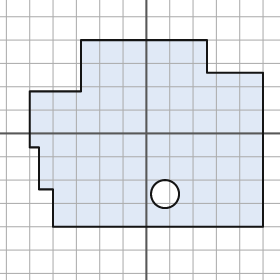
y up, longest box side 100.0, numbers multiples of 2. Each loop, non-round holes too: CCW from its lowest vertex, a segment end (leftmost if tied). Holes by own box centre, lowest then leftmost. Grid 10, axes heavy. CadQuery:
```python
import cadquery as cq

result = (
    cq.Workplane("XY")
    .moveTo(-40.0, -40.0)
    .lineTo(50.0, -40.0)
    .lineTo(50.0, 26.0)
    .lineTo(26.0, 26.0)
    .lineTo(26.0, 40.0)
    .lineTo(-28.0, 40.0)
    .lineTo(-28.0, 18.0)
    .lineTo(-50.0, 18.0)
    .lineTo(-50.0, -6.0)
    .lineTo(-46.0, -6.0)
    .lineTo(-46.0, -24.0)
    .lineTo(-40.0, -24.0)
    .close()
    .moveTo(8.0, -26.0)
    .circle(6.0)
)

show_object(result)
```